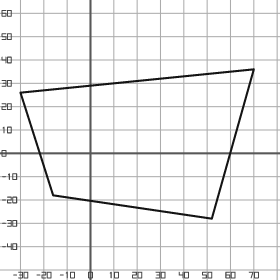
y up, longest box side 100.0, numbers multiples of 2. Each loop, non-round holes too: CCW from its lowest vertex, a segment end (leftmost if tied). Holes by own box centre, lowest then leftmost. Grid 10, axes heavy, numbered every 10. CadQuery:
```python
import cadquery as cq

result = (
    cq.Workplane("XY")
    .moveTo(52.0, -28.0)
    .lineTo(70.0, 36.0)
    .lineTo(-30.0, 26.0)
    .lineTo(-16.0, -18.0)
    .close()
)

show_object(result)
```